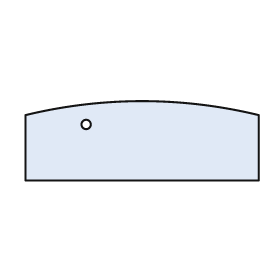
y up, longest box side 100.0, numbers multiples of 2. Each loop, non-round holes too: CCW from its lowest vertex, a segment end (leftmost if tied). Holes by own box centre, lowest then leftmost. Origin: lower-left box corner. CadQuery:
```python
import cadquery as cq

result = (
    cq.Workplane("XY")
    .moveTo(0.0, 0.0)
    .lineTo(100.0, 0.0)
    .lineTo(100.0, 28.0)
    .threePointArc((50.0, 34.0), (0.0, 28.0))
    .close()
    .moveTo(26.0, 24.0)
    .circle(2.0)
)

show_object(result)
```